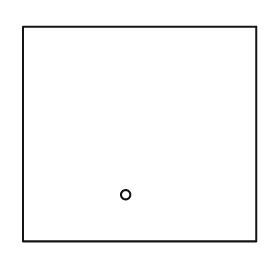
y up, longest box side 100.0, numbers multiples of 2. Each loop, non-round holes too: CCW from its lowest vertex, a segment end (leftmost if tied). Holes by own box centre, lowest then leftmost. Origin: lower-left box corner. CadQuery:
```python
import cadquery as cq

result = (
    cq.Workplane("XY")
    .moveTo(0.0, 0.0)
    .lineTo(100.0, 0.0)
    .lineTo(100.0, 92.0)
    .lineTo(0.0, 92.0)
    .close()
    .moveTo(44.0, 20.0)
    .circle(2.0)
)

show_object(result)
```